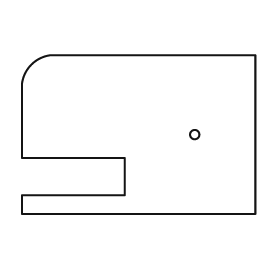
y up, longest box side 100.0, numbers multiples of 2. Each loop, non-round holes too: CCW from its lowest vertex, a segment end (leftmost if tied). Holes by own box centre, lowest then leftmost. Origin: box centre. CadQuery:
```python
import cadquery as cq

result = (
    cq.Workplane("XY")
    .moveTo(-50.0, -34.0)
    .lineTo(50.0, -34.0)
    .lineTo(50.0, 34.0)
    .lineTo(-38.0, 34.0)
    .threePointArc((-46.0, 30.0), (-50.0, 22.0))
    .lineTo(-50.0, -10.0)
    .lineTo(-6.0, -10.0)
    .lineTo(-6.0, -26.0)
    .lineTo(-50.0, -26.0)
    .close()
    .moveTo(24.0, 0.0)
    .circle(2.0)
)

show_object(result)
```